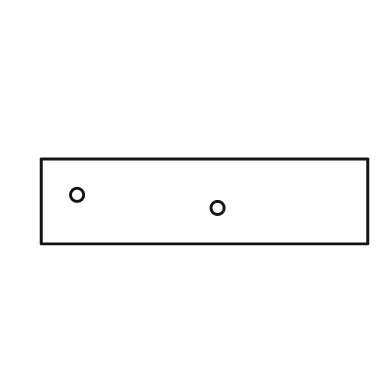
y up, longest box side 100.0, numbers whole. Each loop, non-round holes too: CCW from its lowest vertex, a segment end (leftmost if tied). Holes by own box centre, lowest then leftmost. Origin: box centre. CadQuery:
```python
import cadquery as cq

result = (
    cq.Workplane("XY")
    .moveTo(-50.0, -13.0)
    .lineTo(50.0, -13.0)
    .lineTo(50.0, 13.0)
    .lineTo(-50.0, 13.0)
    .close()
    .moveTo(4.0, -2.0)
    .circle(2.0)
    .moveTo(-39.0, 2.0)
    .circle(2.0)
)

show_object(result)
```